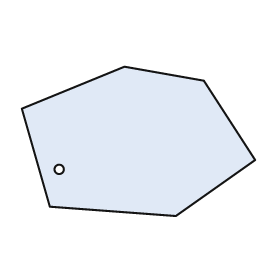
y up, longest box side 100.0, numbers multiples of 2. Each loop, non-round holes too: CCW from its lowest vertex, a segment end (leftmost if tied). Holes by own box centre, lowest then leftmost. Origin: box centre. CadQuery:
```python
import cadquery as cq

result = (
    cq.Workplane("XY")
    .moveTo(16.0, -32.0)
    .lineTo(50.0, -8.0)
    .lineTo(28.0, 26.0)
    .lineTo(-6.0, 32.0)
    .lineTo(-50.0, 14.0)
    .lineTo(-38.0, -28.0)
    .close()
    .moveTo(-34.0, -12.0)
    .circle(2.0)
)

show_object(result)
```